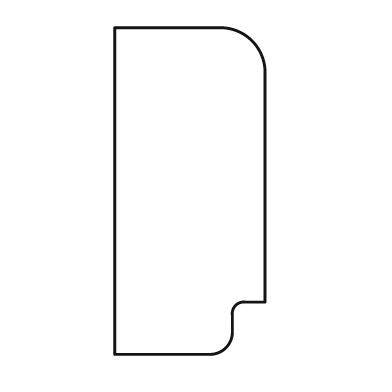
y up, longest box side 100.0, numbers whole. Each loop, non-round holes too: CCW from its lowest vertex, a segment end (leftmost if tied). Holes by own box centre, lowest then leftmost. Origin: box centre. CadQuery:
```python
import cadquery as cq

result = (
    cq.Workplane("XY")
    .moveTo(-23.0, -50.0)
    .lineTo(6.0, -50.0)
    .threePointArc((11.0, -48.0), (13.0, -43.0))
    .lineTo(13.0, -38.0)
    .threePointArc((14.0, -35.0), (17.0, -34.0))
    .lineTo(23.0, -34.0)
    .lineTo(23.0, 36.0)
    .threePointArc((19.0, 46.0), (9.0, 50.0))
    .lineTo(-23.0, 50.0)
    .close()
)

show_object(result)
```